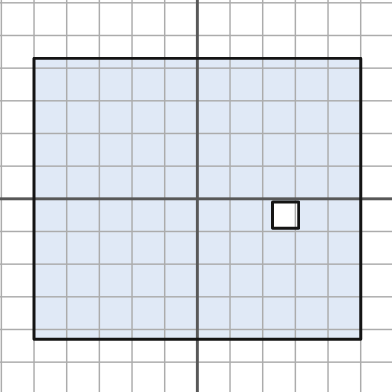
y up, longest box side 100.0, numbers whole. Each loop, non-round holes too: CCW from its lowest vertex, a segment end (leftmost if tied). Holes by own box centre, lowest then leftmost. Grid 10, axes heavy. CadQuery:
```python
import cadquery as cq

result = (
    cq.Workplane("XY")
    .moveTo(-50.0, -43.0)
    .lineTo(50.0, -43.0)
    .lineTo(50.0, 43.0)
    .lineTo(-50.0, 43.0)
    .close()
    .moveTo(23.0, -9.0)
    .lineTo(31.0, -9.0)
    .lineTo(31.0, -1.0)
    .lineTo(23.0, -1.0)
    .close()
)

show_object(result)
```